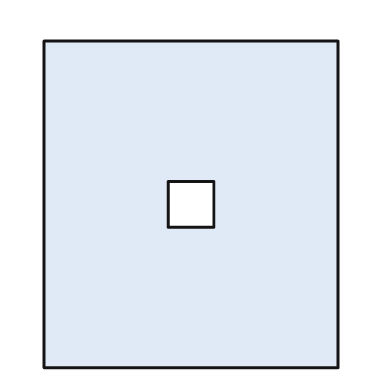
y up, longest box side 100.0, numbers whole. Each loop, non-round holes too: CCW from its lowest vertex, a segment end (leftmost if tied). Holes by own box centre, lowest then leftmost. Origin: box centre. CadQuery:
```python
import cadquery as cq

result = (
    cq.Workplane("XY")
    .moveTo(-45.0, -50.0)
    .lineTo(45.0, -50.0)
    .lineTo(45.0, 50.0)
    .lineTo(-45.0, 50.0)
    .close()
    .moveTo(-7.0, -7.0)
    .lineTo(7.0, -7.0)
    .lineTo(7.0, 7.0)
    .lineTo(-7.0, 7.0)
    .close()
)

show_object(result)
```